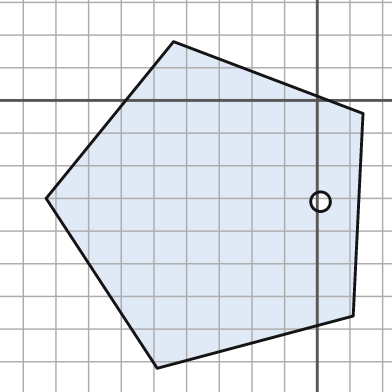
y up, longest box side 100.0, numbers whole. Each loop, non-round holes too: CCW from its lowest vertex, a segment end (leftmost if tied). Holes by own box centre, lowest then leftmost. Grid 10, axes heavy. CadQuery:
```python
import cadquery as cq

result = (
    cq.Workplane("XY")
    .moveTo(-49.0, -82.0)
    .lineTo(11.0, -66.0)
    .lineTo(14.0, -4.0)
    .lineTo(-44.0, 18.0)
    .lineTo(-83.0, -30.0)
    .close()
    .moveTo(1.0, -31.0)
    .circle(3.0)
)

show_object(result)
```